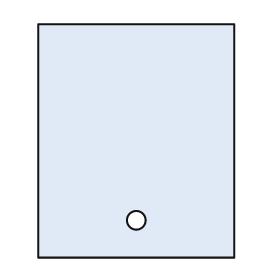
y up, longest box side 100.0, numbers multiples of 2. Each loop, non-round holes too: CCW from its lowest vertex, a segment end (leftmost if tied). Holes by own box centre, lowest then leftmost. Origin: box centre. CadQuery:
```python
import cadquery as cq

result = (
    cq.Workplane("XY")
    .moveTo(-42.0, -50.0)
    .lineTo(42.0, -50.0)
    .lineTo(42.0, 50.0)
    .lineTo(-42.0, 50.0)
    .close()
    .moveTo(0.0, -34.0)
    .circle(4.0)
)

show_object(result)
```